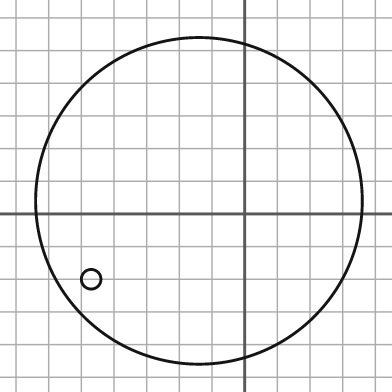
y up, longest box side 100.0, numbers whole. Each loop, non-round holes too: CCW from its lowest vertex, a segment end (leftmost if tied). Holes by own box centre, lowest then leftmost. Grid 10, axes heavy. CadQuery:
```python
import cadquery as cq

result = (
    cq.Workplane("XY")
    .moveTo(-14.0, 4.0)
    .circle(50.0)
    .moveTo(-47.0, -20.0)
    .circle(3.0)
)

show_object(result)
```